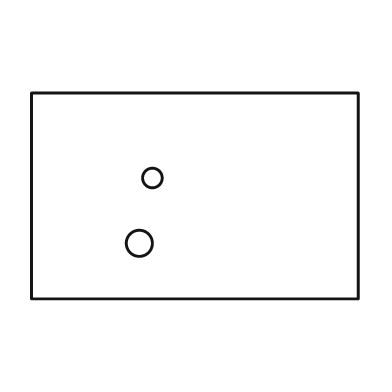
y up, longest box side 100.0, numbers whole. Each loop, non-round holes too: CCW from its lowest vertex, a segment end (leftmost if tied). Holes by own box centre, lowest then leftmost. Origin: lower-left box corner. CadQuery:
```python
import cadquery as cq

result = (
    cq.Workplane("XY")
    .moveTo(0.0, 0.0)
    .lineTo(100.0, 0.0)
    .lineTo(100.0, 63.0)
    .lineTo(0.0, 63.0)
    .close()
    .moveTo(33.0, 17.0)
    .circle(4.0)
    .moveTo(37.0, 37.0)
    .circle(3.0)
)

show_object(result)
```